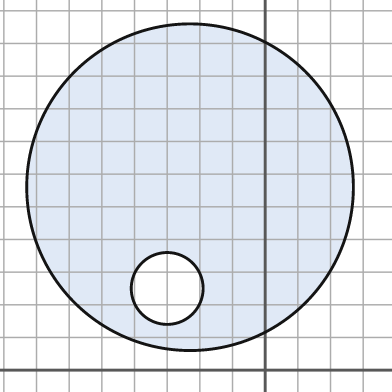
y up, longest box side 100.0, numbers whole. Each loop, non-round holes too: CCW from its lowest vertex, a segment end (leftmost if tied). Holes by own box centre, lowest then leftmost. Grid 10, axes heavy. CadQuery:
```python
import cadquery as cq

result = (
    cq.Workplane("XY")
    .moveTo(-23.0, 56.0)
    .circle(50.0)
    .moveTo(-30.0, 25.0)
    .circle(11.0)
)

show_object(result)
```